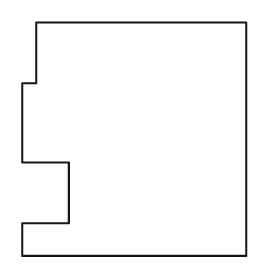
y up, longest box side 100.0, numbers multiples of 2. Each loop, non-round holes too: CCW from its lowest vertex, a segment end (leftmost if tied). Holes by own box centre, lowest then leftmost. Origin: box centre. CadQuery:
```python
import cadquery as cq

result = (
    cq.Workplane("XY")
    .moveTo(-48.0, -50.0)
    .lineTo(48.0, -50.0)
    .lineTo(48.0, 50.0)
    .lineTo(-42.0, 50.0)
    .lineTo(-42.0, 24.0)
    .lineTo(-48.0, 24.0)
    .lineTo(-48.0, -10.0)
    .lineTo(-28.0, -10.0)
    .lineTo(-28.0, -36.0)
    .lineTo(-48.0, -36.0)
    .close()
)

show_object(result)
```